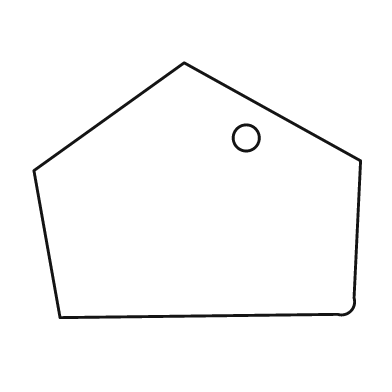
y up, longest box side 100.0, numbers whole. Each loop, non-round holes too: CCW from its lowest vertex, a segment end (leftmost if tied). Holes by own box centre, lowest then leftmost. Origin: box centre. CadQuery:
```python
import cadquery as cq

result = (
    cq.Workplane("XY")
    .moveTo(-42.0, -39.0)
    .lineTo(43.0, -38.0)
    .threePointArc((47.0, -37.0), (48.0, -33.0))
    .lineTo(50.0, 9.0)
    .lineTo(-4.0, 39.0)
    .lineTo(-50.0, 6.0)
    .close()
    .moveTo(15.0, 16.0)
    .circle(4.0)
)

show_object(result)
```